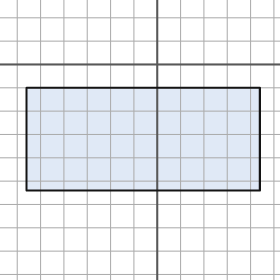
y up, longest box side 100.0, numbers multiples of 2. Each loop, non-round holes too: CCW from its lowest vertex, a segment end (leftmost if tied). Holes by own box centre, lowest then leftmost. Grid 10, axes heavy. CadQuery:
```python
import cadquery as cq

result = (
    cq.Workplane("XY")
    .moveTo(-56.0, -54.0)
    .lineTo(44.0, -54.0)
    .lineTo(44.0, -10.0)
    .lineTo(-56.0, -10.0)
    .close()
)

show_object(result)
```